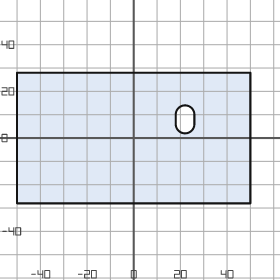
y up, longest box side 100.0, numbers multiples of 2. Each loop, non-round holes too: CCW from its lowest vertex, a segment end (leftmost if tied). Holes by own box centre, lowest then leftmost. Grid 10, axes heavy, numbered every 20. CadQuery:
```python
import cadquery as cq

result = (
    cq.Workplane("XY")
    .moveTo(-50.0, -28.0)
    .lineTo(50.0, -28.0)
    .lineTo(50.0, 28.0)
    .lineTo(-50.0, 28.0)
    .close()
    .moveTo(18.0, 6.0)
    .threePointArc((22.0, 2.0), (26.0, 6.0))
    .lineTo(26.0, 10.0)
    .threePointArc((22.0, 14.0), (18.0, 10.0))
    .close()
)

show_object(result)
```